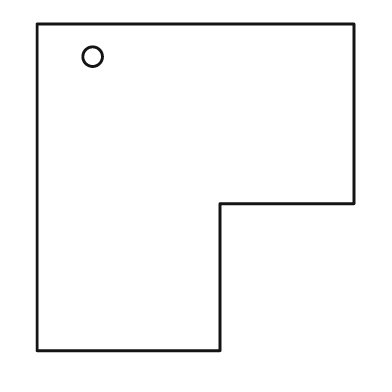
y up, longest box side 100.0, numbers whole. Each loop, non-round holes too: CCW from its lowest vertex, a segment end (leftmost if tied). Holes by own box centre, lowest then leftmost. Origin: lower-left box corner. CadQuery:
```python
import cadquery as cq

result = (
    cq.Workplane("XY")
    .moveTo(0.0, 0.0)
    .lineTo(56.0, 0.0)
    .lineTo(56.0, 45.0)
    .lineTo(97.0, 45.0)
    .lineTo(97.0, 100.0)
    .lineTo(0.0, 100.0)
    .close()
    .moveTo(17.0, 90.0)
    .circle(3.0)
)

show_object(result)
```